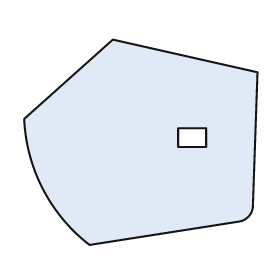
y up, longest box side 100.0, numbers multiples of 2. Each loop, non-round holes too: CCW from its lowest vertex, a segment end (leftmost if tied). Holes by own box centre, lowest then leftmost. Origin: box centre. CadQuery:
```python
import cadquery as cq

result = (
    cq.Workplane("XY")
    .moveTo(-22.0, -44.0)
    .lineTo(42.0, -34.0)
    .threePointArc((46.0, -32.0), (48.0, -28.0))
    .lineTo(50.0, 30.0)
    .lineTo(-12.0, 44.0)
    .lineTo(-50.0, 10.0)
    .threePointArc((-42.0, -20.0), (-22.0, -44.0))
    .close()
    .moveTo(16.0, -2.0)
    .lineTo(28.0, -2.0)
    .lineTo(28.0, 6.0)
    .lineTo(16.0, 6.0)
    .close()
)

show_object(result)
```